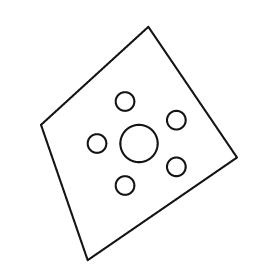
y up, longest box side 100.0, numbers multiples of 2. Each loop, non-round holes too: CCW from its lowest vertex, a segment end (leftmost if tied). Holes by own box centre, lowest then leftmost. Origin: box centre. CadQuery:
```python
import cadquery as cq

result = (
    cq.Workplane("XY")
    .moveTo(-22.0, -50.0)
    .lineTo(42.0, -6.0)
    .lineTo(4.0, 50.0)
    .lineTo(-42.0, 8.0)
    .close()
    .moveTo(-6.0, -18.0)
    .circle(4.0)
    .moveTo(16.0, -10.0)
    .circle(4.0)
    .moveTo(-18.0, 0.0)
    .circle(4.0)
    .moveTo(0.0, 0.0)
    .circle(8.0)
    .moveTo(16.0, 10.0)
    .circle(4.0)
    .moveTo(-6.0, 18.0)
    .circle(4.0)
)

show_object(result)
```